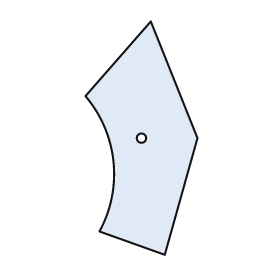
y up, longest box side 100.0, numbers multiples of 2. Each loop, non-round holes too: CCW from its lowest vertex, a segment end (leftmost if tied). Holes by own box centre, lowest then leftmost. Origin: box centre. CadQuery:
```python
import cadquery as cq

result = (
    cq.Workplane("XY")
    .moveTo(10.0, -50.0)
    .lineTo(24.0, 0.0)
    .lineTo(4.0, 50.0)
    .lineTo(-24.0, 18.0)
    .threePointArc((-12.0, -10.0), (-18.0, -40.0))
    .close()
    .moveTo(0.0, 0.0)
    .circle(2.0)
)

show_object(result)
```